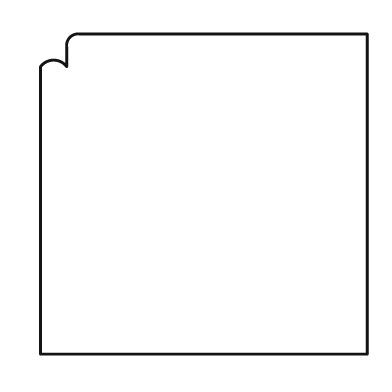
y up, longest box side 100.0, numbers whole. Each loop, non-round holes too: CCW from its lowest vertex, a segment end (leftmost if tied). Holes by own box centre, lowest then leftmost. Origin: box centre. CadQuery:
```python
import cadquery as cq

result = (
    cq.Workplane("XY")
    .moveTo(-50.0, -49.0)
    .lineTo(50.0, -49.0)
    .lineTo(50.0, 49.0)
    .lineTo(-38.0, 49.0)
    .threePointArc((-41.0, 48.0), (-42.0, 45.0))
    .lineTo(-42.0, 39.0)
    .threePointArc((-46.0, 41.0), (-50.0, 39.0))
    .close()
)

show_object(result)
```